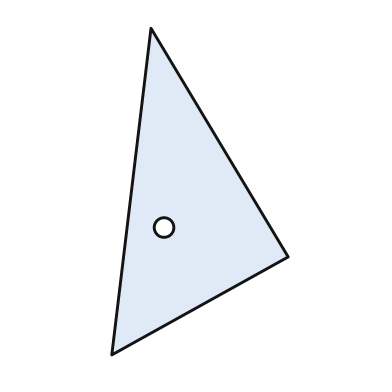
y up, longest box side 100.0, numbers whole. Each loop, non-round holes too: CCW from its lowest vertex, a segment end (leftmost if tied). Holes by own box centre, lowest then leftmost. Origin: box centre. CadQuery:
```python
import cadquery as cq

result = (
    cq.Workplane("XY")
    .moveTo(-27.0, -50.0)
    .lineTo(27.0, -20.0)
    .lineTo(-15.0, 50.0)
    .close()
    .moveTo(-11.0, -11.0)
    .circle(3.0)
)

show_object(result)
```